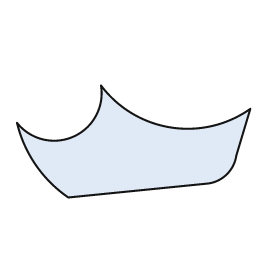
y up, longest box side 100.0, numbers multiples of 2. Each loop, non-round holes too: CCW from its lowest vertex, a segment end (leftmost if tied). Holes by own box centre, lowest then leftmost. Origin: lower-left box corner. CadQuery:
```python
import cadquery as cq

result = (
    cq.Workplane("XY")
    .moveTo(22.0, 0.0)
    .lineTo(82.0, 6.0)
    .threePointArc((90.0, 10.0), (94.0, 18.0))
    .lineTo(100.0, 38.0)
    .threePointArc((66.0, 30.0), (36.0, 48.0))
    .threePointArc((24.0, 26.0), (0.0, 32.0))
    .threePointArc((8.0, 14.0), (22.0, 0.0))
    .close()
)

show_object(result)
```